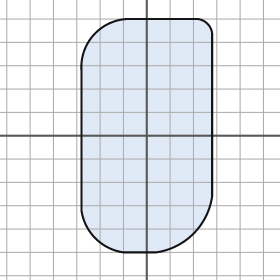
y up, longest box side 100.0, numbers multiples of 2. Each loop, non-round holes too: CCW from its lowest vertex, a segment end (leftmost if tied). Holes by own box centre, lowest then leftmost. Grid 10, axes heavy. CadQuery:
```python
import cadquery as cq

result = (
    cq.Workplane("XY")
    .moveTo(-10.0, -50.0)
    .lineTo(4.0, -50.0)
    .threePointArc((20.0, -42.0), (28.0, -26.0))
    .lineTo(28.0, 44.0)
    .threePointArc((26.0, 48.0), (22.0, 50.0))
    .lineTo(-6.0, 50.0)
    .threePointArc((-22.0, 44.0), (-28.0, 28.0))
    .lineTo(-28.0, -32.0)
    .threePointArc((-22.0, -44.0), (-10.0, -50.0))
    .close()
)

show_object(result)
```